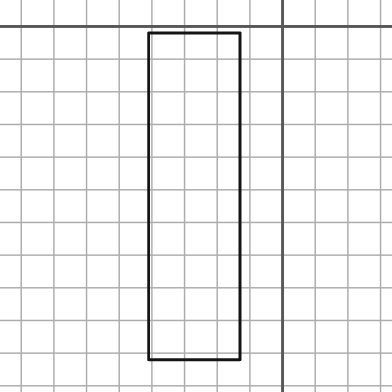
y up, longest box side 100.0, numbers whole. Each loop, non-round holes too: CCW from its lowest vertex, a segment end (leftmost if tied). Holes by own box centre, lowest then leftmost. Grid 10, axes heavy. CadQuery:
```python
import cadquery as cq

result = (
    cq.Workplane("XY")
    .moveTo(-41.0, -102.0)
    .lineTo(-13.0, -102.0)
    .lineTo(-13.0, -2.0)
    .lineTo(-41.0, -2.0)
    .close()
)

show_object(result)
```